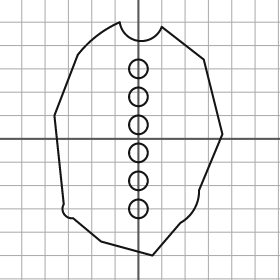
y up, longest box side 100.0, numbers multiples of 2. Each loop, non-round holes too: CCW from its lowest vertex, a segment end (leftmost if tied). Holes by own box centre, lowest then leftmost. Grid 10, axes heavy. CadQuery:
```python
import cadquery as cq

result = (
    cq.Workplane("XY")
    .moveTo(6.0, -50.0)
    .lineTo(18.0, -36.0)
    .threePointArc((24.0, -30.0), (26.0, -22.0))
    .lineTo(36.0, 2.0)
    .lineTo(28.0, 34.0)
    .lineTo(10.0, 48.0)
    .threePointArc((0.0, 42.0), (-8.0, 50.0))
    .threePointArc((-18.0, 44.0), (-26.0, 36.0))
    .lineTo(-36.0, 10.0)
    .lineTo(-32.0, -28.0)
    .threePointArc((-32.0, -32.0), (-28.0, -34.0))
    .lineTo(-16.0, -44.0)
    .close()
    .moveTo(0.0, -30.0)
    .circle(4.0)
    .moveTo(0.0, -18.0)
    .circle(4.0)
    .moveTo(0.0, -6.0)
    .circle(4.0)
    .moveTo(0.0, 6.0)
    .circle(4.0)
    .moveTo(0.0, 18.0)
    .circle(4.0)
    .moveTo(0.0, 30.0)
    .circle(4.0)
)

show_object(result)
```